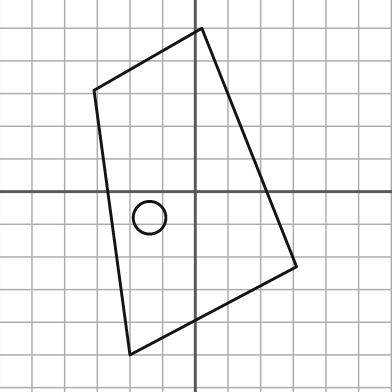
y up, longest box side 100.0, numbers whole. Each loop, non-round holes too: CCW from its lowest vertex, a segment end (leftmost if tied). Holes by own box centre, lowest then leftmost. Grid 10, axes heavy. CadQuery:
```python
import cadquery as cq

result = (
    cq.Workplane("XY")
    .moveTo(-20.0, -50.0)
    .lineTo(31.0, -23.0)
    .lineTo(2.0, 50.0)
    .lineTo(-31.0, 31.0)
    .close()
    .moveTo(-14.0, -8.0)
    .circle(5.0)
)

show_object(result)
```